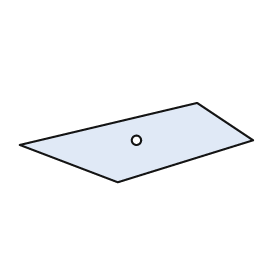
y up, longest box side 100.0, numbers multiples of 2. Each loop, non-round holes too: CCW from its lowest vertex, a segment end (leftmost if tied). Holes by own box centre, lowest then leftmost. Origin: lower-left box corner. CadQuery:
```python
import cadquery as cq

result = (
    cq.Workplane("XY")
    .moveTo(42.0, 0.0)
    .lineTo(100.0, 18.0)
    .lineTo(76.0, 34.0)
    .lineTo(0.0, 16.0)
    .close()
    .moveTo(50.0, 18.0)
    .circle(2.0)
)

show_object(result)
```